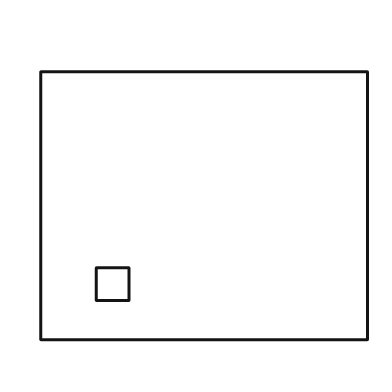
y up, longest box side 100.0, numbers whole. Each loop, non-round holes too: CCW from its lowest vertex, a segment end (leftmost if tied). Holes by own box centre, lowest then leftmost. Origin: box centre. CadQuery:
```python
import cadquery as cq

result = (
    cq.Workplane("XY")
    .moveTo(-50.0, -41.0)
    .lineTo(50.0, -41.0)
    .lineTo(50.0, 41.0)
    .lineTo(-50.0, 41.0)
    .close()
    .moveTo(-33.0, -29.0)
    .lineTo(-23.0, -29.0)
    .lineTo(-23.0, -19.0)
    .lineTo(-33.0, -19.0)
    .close()
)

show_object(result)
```